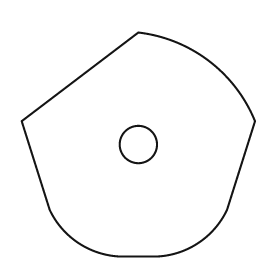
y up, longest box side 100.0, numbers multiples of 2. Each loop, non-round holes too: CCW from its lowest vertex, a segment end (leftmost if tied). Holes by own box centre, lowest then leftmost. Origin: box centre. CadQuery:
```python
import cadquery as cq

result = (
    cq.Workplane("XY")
    .moveTo(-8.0, -48.0)
    .lineTo(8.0, -48.0)
    .threePointArc((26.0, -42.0), (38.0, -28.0))
    .lineTo(50.0, 10.0)
    .threePointArc((30.0, 36.0), (0.0, 48.0))
    .lineTo(-50.0, 10.0)
    .lineTo(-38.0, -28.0)
    .threePointArc((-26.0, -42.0), (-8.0, -48.0))
    .close()
    .moveTo(0.0, 0.0)
    .circle(8.0)
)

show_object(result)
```